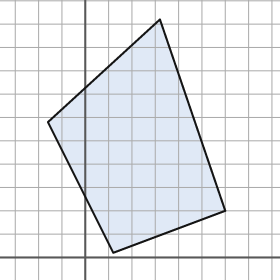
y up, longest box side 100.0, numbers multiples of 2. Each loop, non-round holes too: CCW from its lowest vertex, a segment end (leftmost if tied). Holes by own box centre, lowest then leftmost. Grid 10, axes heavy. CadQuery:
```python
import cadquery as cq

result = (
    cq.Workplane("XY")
    .moveTo(12.0, 2.0)
    .lineTo(60.0, 20.0)
    .lineTo(32.0, 102.0)
    .lineTo(-16.0, 58.0)
    .close()
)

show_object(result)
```